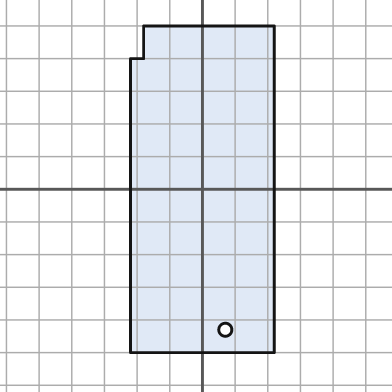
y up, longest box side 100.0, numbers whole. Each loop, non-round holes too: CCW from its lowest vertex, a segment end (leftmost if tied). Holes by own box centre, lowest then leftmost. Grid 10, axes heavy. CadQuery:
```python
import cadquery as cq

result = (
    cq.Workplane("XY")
    .moveTo(-22.0, -50.0)
    .lineTo(22.0, -50.0)
    .lineTo(22.0, 50.0)
    .lineTo(-18.0, 50.0)
    .lineTo(-18.0, 40.0)
    .lineTo(-22.0, 40.0)
    .close()
    .moveTo(7.0, -43.0)
    .circle(2.0)
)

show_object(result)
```